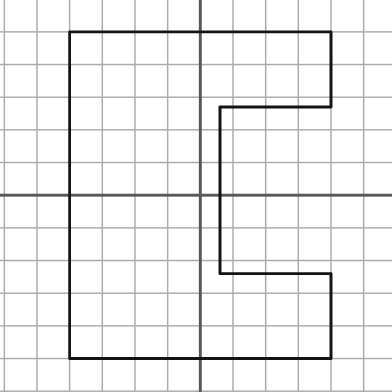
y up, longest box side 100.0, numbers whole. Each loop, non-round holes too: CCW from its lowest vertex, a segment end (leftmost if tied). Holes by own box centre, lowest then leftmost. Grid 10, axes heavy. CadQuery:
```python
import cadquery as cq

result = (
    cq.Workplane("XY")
    .moveTo(-40.0, -50.0)
    .lineTo(40.0, -50.0)
    .lineTo(40.0, -24.0)
    .lineTo(6.0, -24.0)
    .lineTo(6.0, 27.0)
    .lineTo(40.0, 27.0)
    .lineTo(40.0, 50.0)
    .lineTo(-40.0, 50.0)
    .close()
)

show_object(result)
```